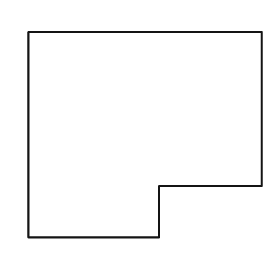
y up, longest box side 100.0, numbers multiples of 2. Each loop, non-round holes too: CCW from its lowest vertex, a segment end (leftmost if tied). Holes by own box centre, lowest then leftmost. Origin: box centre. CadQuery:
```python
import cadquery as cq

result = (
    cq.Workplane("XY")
    .moveTo(-50.0, -44.0)
    .lineTo(6.0, -44.0)
    .lineTo(6.0, -22.0)
    .lineTo(50.0, -22.0)
    .lineTo(50.0, 44.0)
    .lineTo(-50.0, 44.0)
    .close()
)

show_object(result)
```